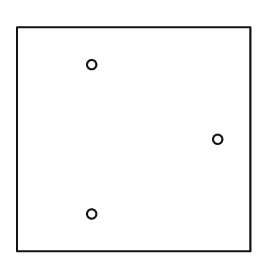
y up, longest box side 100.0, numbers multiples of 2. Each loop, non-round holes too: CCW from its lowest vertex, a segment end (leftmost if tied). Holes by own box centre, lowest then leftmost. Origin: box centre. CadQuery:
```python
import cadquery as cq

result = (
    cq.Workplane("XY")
    .moveTo(-50.0, -48.0)
    .lineTo(50.0, -48.0)
    .lineTo(50.0, 48.0)
    .lineTo(-50.0, 48.0)
    .close()
    .moveTo(-18.0, -32.0)
    .circle(2.0)
    .moveTo(36.0, 0.0)
    .circle(2.0)
    .moveTo(-18.0, 32.0)
    .circle(2.0)
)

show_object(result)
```